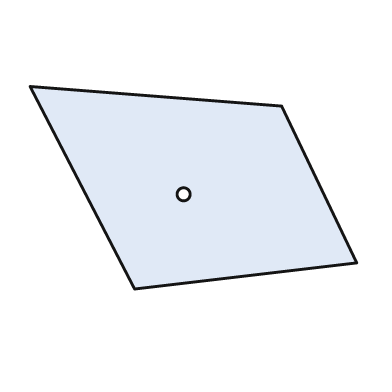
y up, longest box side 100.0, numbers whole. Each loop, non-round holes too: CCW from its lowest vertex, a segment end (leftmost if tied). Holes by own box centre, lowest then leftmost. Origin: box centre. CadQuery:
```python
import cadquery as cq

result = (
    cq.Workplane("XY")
    .moveTo(-18.0, -31.0)
    .lineTo(50.0, -23.0)
    .lineTo(27.0, 25.0)
    .lineTo(-50.0, 31.0)
    .close()
    .moveTo(-3.0, -2.0)
    .circle(2.0)
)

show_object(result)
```